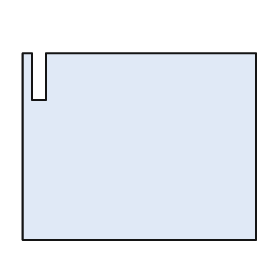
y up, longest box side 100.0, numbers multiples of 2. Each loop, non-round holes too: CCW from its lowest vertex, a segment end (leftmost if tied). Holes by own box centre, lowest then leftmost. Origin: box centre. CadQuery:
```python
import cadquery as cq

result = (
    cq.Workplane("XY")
    .moveTo(-50.0, -40.0)
    .lineTo(50.0, -40.0)
    .lineTo(50.0, 40.0)
    .lineTo(-40.0, 40.0)
    .lineTo(-40.0, 20.0)
    .lineTo(-46.0, 20.0)
    .lineTo(-46.0, 40.0)
    .lineTo(-50.0, 40.0)
    .close()
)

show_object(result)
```